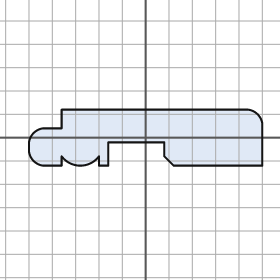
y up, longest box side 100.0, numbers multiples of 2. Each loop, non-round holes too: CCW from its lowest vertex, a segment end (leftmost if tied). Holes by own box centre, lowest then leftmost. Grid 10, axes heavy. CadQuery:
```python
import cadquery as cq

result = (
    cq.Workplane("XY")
    .moveTo(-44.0, -12.0)
    .lineTo(-36.0, -12.0)
    .lineTo(-36.0, -8.0)
    .threePointArc((-28.0, -12.0), (-20.0, -8.0))
    .lineTo(-20.0, -12.0)
    .lineTo(-16.0, -12.0)
    .lineTo(-16.0, -2.0)
    .lineTo(8.0, -2.0)
    .lineTo(8.0, -8.0)
    .lineTo(12.0, -12.0)
    .lineTo(50.0, -12.0)
    .lineTo(50.0, 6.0)
    .threePointArc((48.0, 10.0), (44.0, 12.0))
    .lineTo(-36.0, 12.0)
    .lineTo(-36.0, 4.0)
    .lineTo(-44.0, 4.0)
    .threePointArc((-48.0, 2.0), (-50.0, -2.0))
    .lineTo(-50.0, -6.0)
    .threePointArc((-48.0, -10.0), (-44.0, -12.0))
    .close()
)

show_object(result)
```